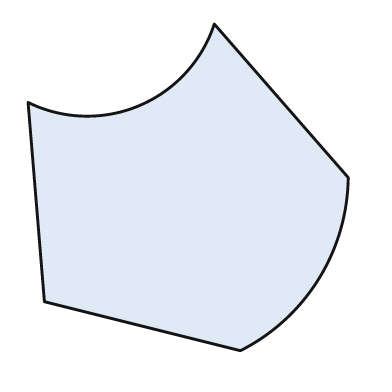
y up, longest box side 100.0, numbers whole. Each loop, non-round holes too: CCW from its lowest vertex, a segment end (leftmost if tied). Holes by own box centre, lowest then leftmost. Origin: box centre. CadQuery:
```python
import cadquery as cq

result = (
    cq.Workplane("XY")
    .moveTo(16.0, -50.0)
    .threePointArc((40.0, -28.0), (49.0, 3.0))
    .lineTo(8.0, 50.0)
    .threePointArc((-15.0, 25.0), (-49.0, 26.0))
    .lineTo(-44.0, -35.0)
    .close()
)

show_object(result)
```